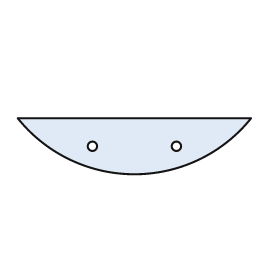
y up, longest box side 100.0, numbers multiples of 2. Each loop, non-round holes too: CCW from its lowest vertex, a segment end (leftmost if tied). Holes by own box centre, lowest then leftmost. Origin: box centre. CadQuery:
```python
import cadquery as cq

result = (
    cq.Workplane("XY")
    .moveTo(-50.0, 12.0)
    .threePointArc((0.0, -12.0), (50.0, 12.0))
    .close()
    .moveTo(-18.0, 0.0)
    .circle(2.0)
    .moveTo(18.0, 0.0)
    .circle(2.0)
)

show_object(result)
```